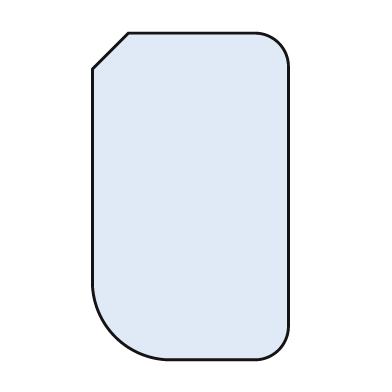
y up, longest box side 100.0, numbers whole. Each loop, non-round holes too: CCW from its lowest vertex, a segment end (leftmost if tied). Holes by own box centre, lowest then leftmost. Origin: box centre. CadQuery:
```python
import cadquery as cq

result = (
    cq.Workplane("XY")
    .moveTo(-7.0, -50.0)
    .lineTo(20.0, -50.0)
    .threePointArc((27.0, -47.0), (30.0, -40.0))
    .lineTo(30.0, 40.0)
    .threePointArc((27.0, 47.0), (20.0, 50.0))
    .lineTo(-19.0, 50.0)
    .lineTo(-30.0, 39.0)
    .lineTo(-30.0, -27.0)
    .threePointArc((-23.0, -43.0), (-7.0, -50.0))
    .close()
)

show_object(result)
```